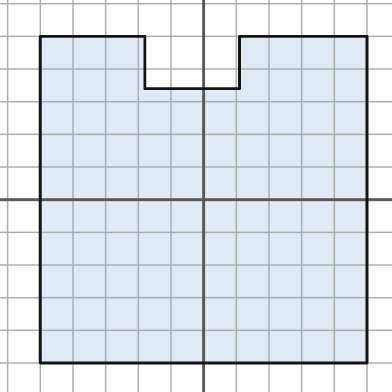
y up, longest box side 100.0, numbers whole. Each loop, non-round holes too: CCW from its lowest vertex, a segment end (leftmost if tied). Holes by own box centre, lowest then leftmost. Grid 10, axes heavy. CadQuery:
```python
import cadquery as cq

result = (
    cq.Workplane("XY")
    .moveTo(-50.0, -50.0)
    .lineTo(50.0, -50.0)
    .lineTo(50.0, 50.0)
    .lineTo(11.0, 50.0)
    .lineTo(11.0, 34.0)
    .lineTo(-18.0, 34.0)
    .lineTo(-18.0, 50.0)
    .lineTo(-50.0, 50.0)
    .close()
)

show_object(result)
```